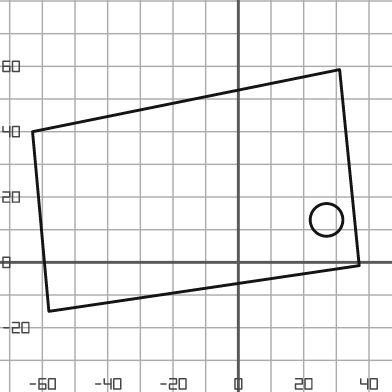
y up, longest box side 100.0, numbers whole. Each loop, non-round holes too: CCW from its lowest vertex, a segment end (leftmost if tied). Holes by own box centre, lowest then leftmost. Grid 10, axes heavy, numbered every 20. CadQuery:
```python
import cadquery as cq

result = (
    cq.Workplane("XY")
    .moveTo(-58.0, -15.0)
    .lineTo(37.0, -1.0)
    .lineTo(31.0, 59.0)
    .lineTo(-63.0, 40.0)
    .close()
    .moveTo(27.0, 13.0)
    .circle(5.0)
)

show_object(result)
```